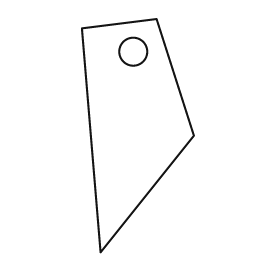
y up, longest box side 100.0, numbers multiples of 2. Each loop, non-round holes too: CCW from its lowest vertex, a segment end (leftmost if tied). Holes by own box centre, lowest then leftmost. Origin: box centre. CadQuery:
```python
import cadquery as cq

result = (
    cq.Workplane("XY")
    .moveTo(-16.0, -50.0)
    .lineTo(24.0, 0.0)
    .lineTo(8.0, 50.0)
    .lineTo(-24.0, 46.0)
    .close()
    .moveTo(-2.0, 36.0)
    .circle(6.0)
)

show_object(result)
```